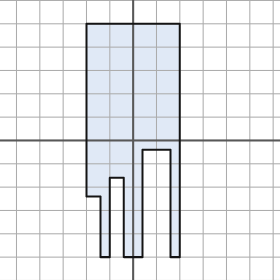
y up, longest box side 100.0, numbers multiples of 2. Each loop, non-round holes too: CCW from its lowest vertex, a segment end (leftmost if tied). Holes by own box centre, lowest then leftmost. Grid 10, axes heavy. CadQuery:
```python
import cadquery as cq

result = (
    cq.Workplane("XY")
    .moveTo(-14.0, -50.0)
    .lineTo(-10.0, -50.0)
    .lineTo(-10.0, -16.0)
    .lineTo(-4.0, -16.0)
    .lineTo(-4.0, -50.0)
    .lineTo(4.0, -50.0)
    .lineTo(4.0, -4.0)
    .lineTo(16.0, -4.0)
    .lineTo(16.0, -50.0)
    .lineTo(20.0, -50.0)
    .lineTo(20.0, 50.0)
    .lineTo(-20.0, 50.0)
    .lineTo(-20.0, -24.0)
    .lineTo(-14.0, -24.0)
    .close()
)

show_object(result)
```